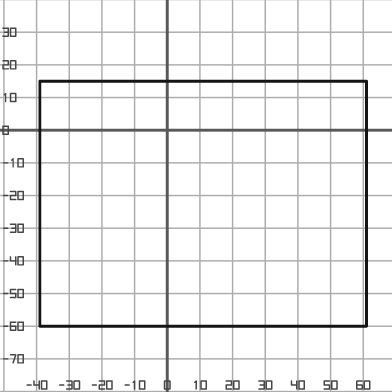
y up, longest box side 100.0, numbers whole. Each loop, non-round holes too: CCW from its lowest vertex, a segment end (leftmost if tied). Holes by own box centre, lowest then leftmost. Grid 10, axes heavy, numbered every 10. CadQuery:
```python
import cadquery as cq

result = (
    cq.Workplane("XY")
    .moveTo(-39.0, -60.0)
    .lineTo(61.0, -60.0)
    .lineTo(61.0, 15.0)
    .lineTo(-39.0, 15.0)
    .close()
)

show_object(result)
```